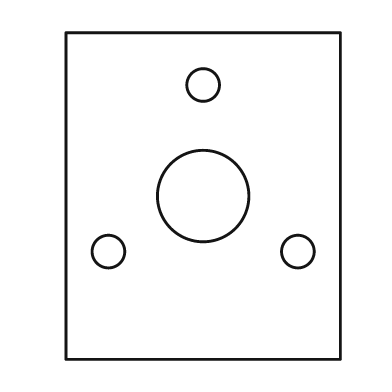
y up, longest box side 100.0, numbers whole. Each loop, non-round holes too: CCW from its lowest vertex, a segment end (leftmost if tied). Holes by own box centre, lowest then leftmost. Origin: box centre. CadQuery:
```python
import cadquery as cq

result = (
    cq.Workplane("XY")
    .moveTo(-42.0, -50.0)
    .lineTo(42.0, -50.0)
    .lineTo(42.0, 50.0)
    .lineTo(-42.0, 50.0)
    .close()
    .moveTo(-29.0, -17.0)
    .circle(5.0)
    .moveTo(29.0, -17.0)
    .circle(5.0)
    .moveTo(0.0, 0.0)
    .circle(14.0)
    .moveTo(0.0, 34.0)
    .circle(5.0)
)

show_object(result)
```